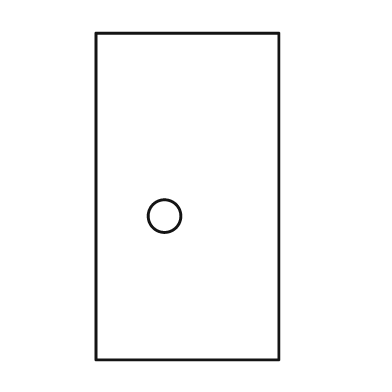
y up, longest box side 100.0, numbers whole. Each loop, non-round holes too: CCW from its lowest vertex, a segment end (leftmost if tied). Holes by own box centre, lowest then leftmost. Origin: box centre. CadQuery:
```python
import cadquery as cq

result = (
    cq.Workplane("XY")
    .moveTo(-28.0, -50.0)
    .lineTo(28.0, -50.0)
    .lineTo(28.0, 50.0)
    .lineTo(-28.0, 50.0)
    .close()
    .moveTo(-7.0, -6.0)
    .circle(5.0)
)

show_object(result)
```